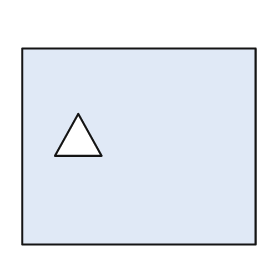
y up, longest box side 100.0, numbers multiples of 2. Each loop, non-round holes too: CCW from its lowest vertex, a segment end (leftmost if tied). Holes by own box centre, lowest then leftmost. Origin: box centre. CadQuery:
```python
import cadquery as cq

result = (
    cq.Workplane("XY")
    .moveTo(-50.0, -42.0)
    .lineTo(50.0, -42.0)
    .lineTo(50.0, 42.0)
    .lineTo(-50.0, 42.0)
    .close()
    .moveTo(-36.0, -4.0)
    .lineTo(-16.0, -4.0)
    .lineTo(-26.0, 14.0)
    .close()
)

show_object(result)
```